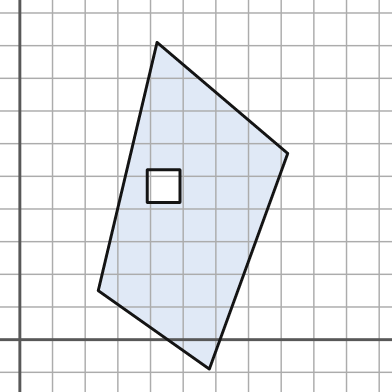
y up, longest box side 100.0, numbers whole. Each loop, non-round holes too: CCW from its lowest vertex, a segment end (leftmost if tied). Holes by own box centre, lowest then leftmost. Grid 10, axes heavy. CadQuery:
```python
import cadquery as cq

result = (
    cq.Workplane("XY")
    .moveTo(58.0, -9.0)
    .lineTo(82.0, 57.0)
    .lineTo(42.0, 91.0)
    .lineTo(24.0, 15.0)
    .close()
    .moveTo(39.0, 42.0)
    .lineTo(49.0, 42.0)
    .lineTo(49.0, 52.0)
    .lineTo(39.0, 52.0)
    .close()
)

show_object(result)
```